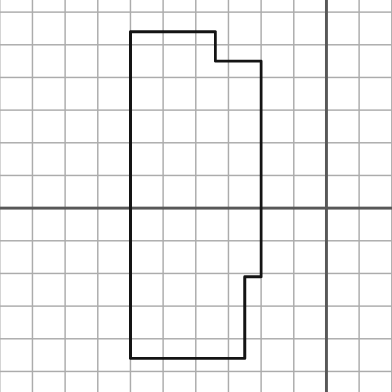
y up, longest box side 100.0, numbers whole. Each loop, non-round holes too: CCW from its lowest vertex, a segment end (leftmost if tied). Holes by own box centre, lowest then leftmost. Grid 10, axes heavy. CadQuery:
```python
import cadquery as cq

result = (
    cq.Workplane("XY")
    .moveTo(-60.0, -46.0)
    .lineTo(-25.0, -46.0)
    .lineTo(-25.0, -21.0)
    .lineTo(-20.0, -21.0)
    .lineTo(-20.0, 45.0)
    .lineTo(-34.0, 45.0)
    .lineTo(-34.0, 54.0)
    .lineTo(-60.0, 54.0)
    .close()
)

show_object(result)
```